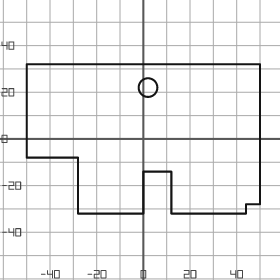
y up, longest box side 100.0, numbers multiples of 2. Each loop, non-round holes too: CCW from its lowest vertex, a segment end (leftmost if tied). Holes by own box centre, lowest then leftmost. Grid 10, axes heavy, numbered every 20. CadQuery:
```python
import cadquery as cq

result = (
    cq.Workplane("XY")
    .moveTo(-28.0, -32.0)
    .lineTo(0.0, -32.0)
    .lineTo(0.0, -14.0)
    .lineTo(12.0, -14.0)
    .lineTo(12.0, -32.0)
    .lineTo(44.0, -32.0)
    .lineTo(44.0, -28.0)
    .lineTo(50.0, -28.0)
    .lineTo(50.0, 32.0)
    .lineTo(-50.0, 32.0)
    .lineTo(-50.0, -8.0)
    .lineTo(-28.0, -8.0)
    .close()
    .moveTo(2.0, 22.0)
    .circle(4.0)
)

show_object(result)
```